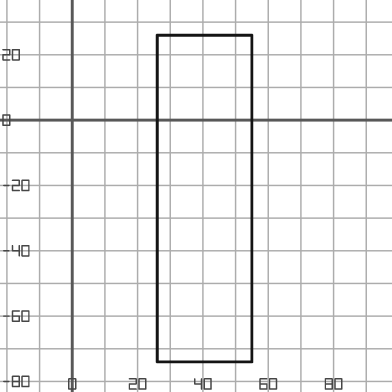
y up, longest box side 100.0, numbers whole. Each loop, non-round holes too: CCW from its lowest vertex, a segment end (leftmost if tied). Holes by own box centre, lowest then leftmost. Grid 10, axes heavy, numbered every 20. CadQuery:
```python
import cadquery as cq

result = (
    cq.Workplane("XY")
    .moveTo(26.0, -74.0)
    .lineTo(55.0, -74.0)
    .lineTo(55.0, 26.0)
    .lineTo(26.0, 26.0)
    .close()
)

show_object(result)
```